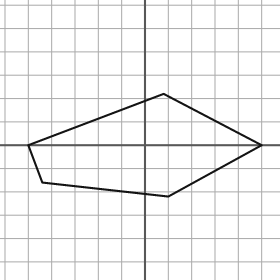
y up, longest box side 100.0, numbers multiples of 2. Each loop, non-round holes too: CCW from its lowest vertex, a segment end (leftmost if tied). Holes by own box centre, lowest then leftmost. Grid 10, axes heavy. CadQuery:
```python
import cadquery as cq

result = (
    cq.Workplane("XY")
    .moveTo(10.0, -22.0)
    .lineTo(50.0, 0.0)
    .lineTo(8.0, 22.0)
    .lineTo(-50.0, 0.0)
    .lineTo(-44.0, -16.0)
    .close()
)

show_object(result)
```